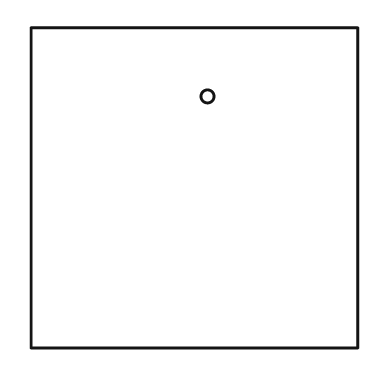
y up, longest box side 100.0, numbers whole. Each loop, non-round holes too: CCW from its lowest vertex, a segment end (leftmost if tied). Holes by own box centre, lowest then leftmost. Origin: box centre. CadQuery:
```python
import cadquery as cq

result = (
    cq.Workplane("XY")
    .moveTo(-50.0, -49.0)
    .lineTo(50.0, -49.0)
    .lineTo(50.0, 49.0)
    .lineTo(-50.0, 49.0)
    .close()
    .moveTo(4.0, 28.0)
    .circle(2.0)
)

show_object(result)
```